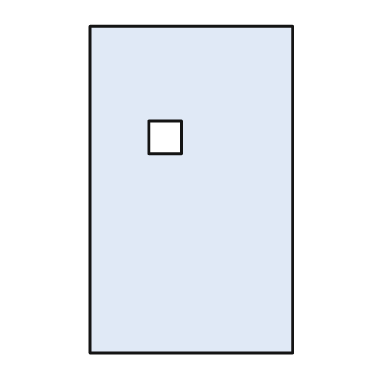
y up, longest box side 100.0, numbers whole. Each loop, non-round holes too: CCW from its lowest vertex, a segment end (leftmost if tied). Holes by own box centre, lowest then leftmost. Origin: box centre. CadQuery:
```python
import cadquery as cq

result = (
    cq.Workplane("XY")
    .moveTo(-31.0, -50.0)
    .lineTo(31.0, -50.0)
    .lineTo(31.0, 50.0)
    .lineTo(-31.0, 50.0)
    .close()
    .moveTo(-13.0, 11.0)
    .lineTo(-3.0, 11.0)
    .lineTo(-3.0, 21.0)
    .lineTo(-13.0, 21.0)
    .close()
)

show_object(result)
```